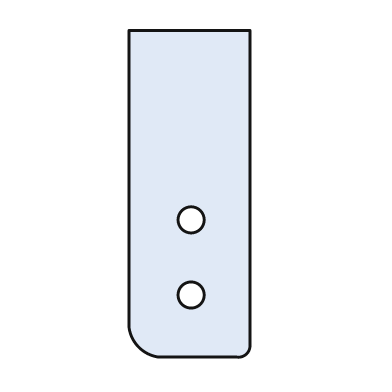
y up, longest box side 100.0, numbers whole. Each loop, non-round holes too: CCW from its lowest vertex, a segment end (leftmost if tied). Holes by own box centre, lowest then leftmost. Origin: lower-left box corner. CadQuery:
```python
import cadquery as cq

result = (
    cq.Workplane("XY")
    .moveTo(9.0, 0.0)
    .lineTo(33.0, 0.0)
    .threePointArc((36.0, 1.0), (37.0, 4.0))
    .lineTo(37.0, 100.0)
    .lineTo(0.0, 100.0)
    .lineTo(0.0, 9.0)
    .threePointArc((3.0, 3.0), (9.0, 0.0))
    .close()
    .moveTo(19.0, 19.0)
    .circle(4.0)
    .moveTo(19.0, 42.0)
    .circle(4.0)
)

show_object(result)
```